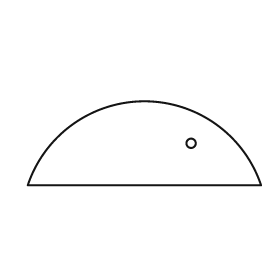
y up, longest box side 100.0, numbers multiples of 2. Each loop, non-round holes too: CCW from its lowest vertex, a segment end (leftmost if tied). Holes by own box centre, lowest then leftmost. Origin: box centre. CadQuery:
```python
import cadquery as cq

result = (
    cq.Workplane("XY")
    .moveTo(-50.0, -18.0)
    .lineTo(50.0, -18.0)
    .threePointArc((0.0, 18.0), (-50.0, -18.0))
    .close()
    .moveTo(20.0, 0.0)
    .circle(2.0)
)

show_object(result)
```